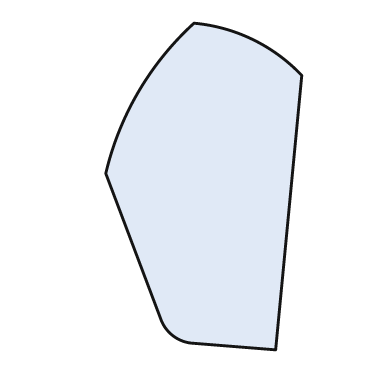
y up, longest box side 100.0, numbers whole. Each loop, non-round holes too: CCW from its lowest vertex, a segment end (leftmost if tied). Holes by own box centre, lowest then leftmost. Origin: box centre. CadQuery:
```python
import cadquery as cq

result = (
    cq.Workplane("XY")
    .moveTo(22.0, -50.0)
    .lineTo(30.0, 34.0)
    .threePointArc((15.0, 45.0), (-3.0, 50.0))
    .threePointArc((-20.0, 29.0), (-30.0, 4.0))
    .lineTo(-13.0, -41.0)
    .threePointArc((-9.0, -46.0), (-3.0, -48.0))
    .close()
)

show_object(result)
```